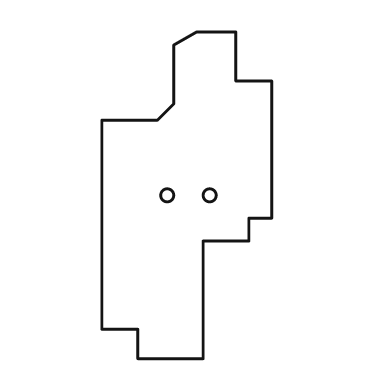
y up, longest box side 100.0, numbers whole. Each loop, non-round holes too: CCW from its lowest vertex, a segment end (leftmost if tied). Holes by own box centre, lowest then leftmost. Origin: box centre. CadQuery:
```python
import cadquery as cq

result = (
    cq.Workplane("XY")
    .moveTo(-15.0, -50.0)
    .lineTo(5.0, -50.0)
    .lineTo(5.0, -14.0)
    .lineTo(19.0, -14.0)
    .lineTo(19.0, -7.0)
    .lineTo(26.0, -7.0)
    .lineTo(26.0, 35.0)
    .lineTo(15.0, 35.0)
    .lineTo(15.0, 50.0)
    .lineTo(3.0, 50.0)
    .lineTo(-4.0, 46.0)
    .lineTo(-4.0, 28.0)
    .lineTo(-9.0, 23.0)
    .lineTo(-26.0, 23.0)
    .lineTo(-26.0, -41.0)
    .lineTo(-15.0, -41.0)
    .close()
    .moveTo(-6.0, 0.0)
    .circle(2.0)
    .moveTo(7.0, 0.0)
    .circle(2.0)
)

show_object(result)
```